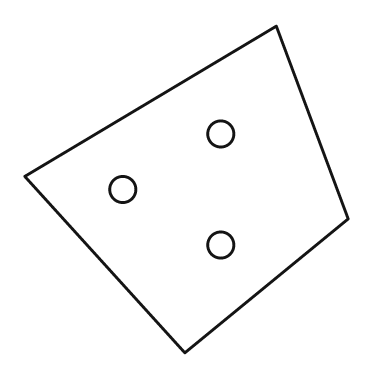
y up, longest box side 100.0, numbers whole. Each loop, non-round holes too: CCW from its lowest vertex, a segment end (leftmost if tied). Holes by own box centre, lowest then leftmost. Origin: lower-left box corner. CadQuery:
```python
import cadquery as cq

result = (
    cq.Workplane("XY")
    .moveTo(49.0, 0.0)
    .lineTo(99.0, 41.0)
    .lineTo(77.0, 100.0)
    .lineTo(0.0, 54.0)
    .close()
    .moveTo(60.0, 33.0)
    .circle(4.0)
    .moveTo(30.0, 50.0)
    .circle(4.0)
    .moveTo(60.0, 67.0)
    .circle(4.0)
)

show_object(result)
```